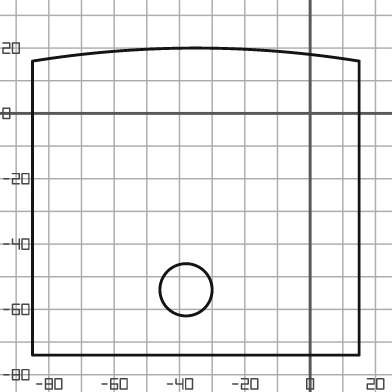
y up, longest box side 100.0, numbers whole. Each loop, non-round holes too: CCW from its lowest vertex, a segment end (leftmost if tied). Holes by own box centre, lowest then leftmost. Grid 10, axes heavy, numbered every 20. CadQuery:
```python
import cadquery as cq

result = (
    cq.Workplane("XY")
    .moveTo(-85.0, -74.0)
    .lineTo(15.0, -74.0)
    .lineTo(15.0, 16.0)
    .threePointArc((-35.0, 20.0), (-85.0, 16.0))
    .close()
    .moveTo(-38.0, -54.0)
    .circle(8.0)
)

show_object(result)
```